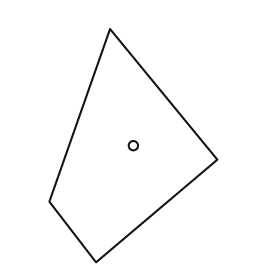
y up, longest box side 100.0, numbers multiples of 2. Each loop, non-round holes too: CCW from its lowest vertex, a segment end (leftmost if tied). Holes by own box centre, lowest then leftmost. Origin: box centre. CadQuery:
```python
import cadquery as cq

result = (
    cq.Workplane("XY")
    .moveTo(-16.0, -50.0)
    .lineTo(36.0, -6.0)
    .lineTo(-10.0, 50.0)
    .lineTo(-36.0, -24.0)
    .close()
    .moveTo(0.0, 0.0)
    .circle(2.0)
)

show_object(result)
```